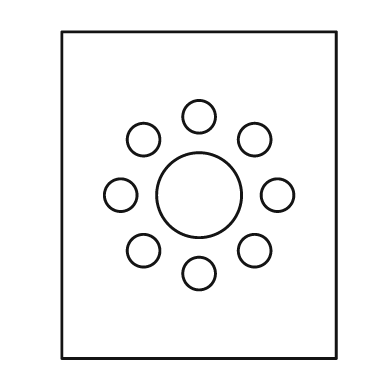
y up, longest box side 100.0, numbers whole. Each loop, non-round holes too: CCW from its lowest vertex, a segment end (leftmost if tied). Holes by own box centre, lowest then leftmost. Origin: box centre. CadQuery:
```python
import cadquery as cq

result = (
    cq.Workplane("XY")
    .moveTo(-42.0, -50.0)
    .lineTo(42.0, -50.0)
    .lineTo(42.0, 50.0)
    .lineTo(-42.0, 50.0)
    .close()
    .moveTo(0.0, -24.0)
    .circle(5.0)
    .moveTo(-17.0, -17.0)
    .circle(5.0)
    .moveTo(17.0, -17.0)
    .circle(5.0)
    .moveTo(-24.0, 0.0)
    .circle(5.0)
    .moveTo(0.0, 0.0)
    .circle(13.0)
    .moveTo(24.0, 0.0)
    .circle(5.0)
    .moveTo(-17.0, 17.0)
    .circle(5.0)
    .moveTo(17.0, 17.0)
    .circle(5.0)
    .moveTo(0.0, 24.0)
    .circle(5.0)
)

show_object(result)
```